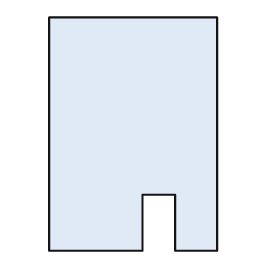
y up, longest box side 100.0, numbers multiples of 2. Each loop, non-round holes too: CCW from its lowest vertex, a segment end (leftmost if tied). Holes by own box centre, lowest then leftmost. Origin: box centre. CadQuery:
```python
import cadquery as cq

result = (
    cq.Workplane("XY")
    .moveTo(-36.0, -50.0)
    .lineTo(4.0, -50.0)
    .lineTo(4.0, -26.0)
    .lineTo(18.0, -26.0)
    .lineTo(18.0, -50.0)
    .lineTo(36.0, -50.0)
    .lineTo(36.0, 50.0)
    .lineTo(-36.0, 50.0)
    .close()
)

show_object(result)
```